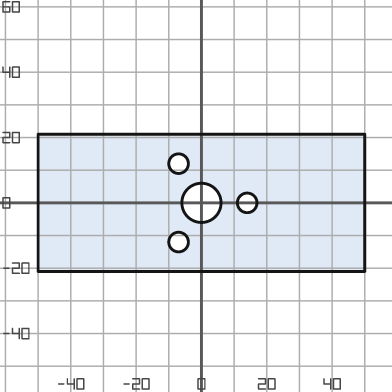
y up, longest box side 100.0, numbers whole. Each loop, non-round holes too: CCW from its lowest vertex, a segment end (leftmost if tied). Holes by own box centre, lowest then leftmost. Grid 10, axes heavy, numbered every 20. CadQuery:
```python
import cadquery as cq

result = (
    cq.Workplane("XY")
    .moveTo(-50.0, -21.0)
    .lineTo(50.0, -21.0)
    .lineTo(50.0, 21.0)
    .lineTo(-50.0, 21.0)
    .close()
    .moveTo(-7.0, -12.0)
    .circle(3.0)
    .moveTo(0.0, 0.0)
    .circle(6.0)
    .moveTo(14.0, 0.0)
    .circle(3.0)
    .moveTo(-7.0, 12.0)
    .circle(3.0)
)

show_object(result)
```